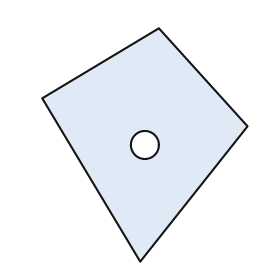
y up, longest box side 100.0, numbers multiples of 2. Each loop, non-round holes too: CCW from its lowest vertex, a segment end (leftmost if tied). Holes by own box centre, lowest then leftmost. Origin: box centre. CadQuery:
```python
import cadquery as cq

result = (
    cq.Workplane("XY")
    .moveTo(-2.0, -50.0)
    .lineTo(44.0, 8.0)
    .lineTo(6.0, 50.0)
    .lineTo(-44.0, 20.0)
    .close()
    .moveTo(0.0, 0.0)
    .circle(6.0)
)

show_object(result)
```